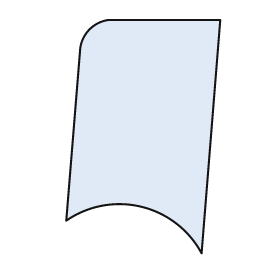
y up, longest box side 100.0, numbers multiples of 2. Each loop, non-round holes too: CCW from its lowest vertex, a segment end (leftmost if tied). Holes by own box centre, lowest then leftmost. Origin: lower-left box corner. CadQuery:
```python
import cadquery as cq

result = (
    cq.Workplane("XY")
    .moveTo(58.0, 0.0)
    .lineTo(66.0, 100.0)
    .lineTo(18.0, 100.0)
    .threePointArc((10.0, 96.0), (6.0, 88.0))
    .lineTo(0.0, 14.0)
    .threePointArc((32.0, 20.0), (58.0, 0.0))
    .close()
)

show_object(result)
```